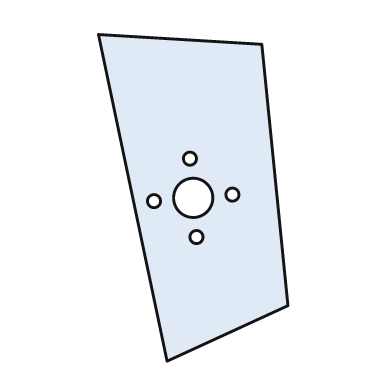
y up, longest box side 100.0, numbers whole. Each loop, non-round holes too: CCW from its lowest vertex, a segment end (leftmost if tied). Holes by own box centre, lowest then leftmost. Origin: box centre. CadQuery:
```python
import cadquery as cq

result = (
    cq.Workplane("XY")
    .moveTo(-8.0, -50.0)
    .lineTo(29.0, -33.0)
    .lineTo(21.0, 47.0)
    .lineTo(-29.0, 50.0)
    .close()
    .moveTo(1.0, -12.0)
    .circle(2.0)
    .moveTo(-12.0, -1.0)
    .circle(2.0)
    .moveTo(0.0, 0.0)
    .circle(6.0)
    .moveTo(12.0, 1.0)
    .circle(2.0)
    .moveTo(-1.0, 12.0)
    .circle(2.0)
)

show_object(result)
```